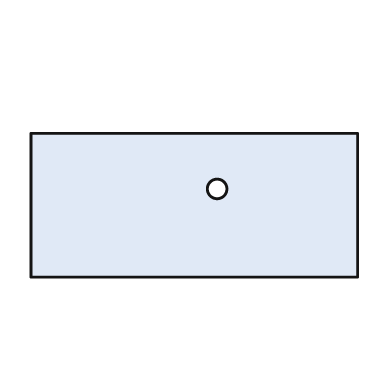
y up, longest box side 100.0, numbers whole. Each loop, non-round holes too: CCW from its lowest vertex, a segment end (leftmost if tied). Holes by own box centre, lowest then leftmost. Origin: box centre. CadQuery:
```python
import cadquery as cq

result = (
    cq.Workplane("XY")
    .moveTo(-50.0, -22.0)
    .lineTo(50.0, -22.0)
    .lineTo(50.0, 22.0)
    .lineTo(-50.0, 22.0)
    .close()
    .moveTo(7.0, 5.0)
    .circle(3.0)
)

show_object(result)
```